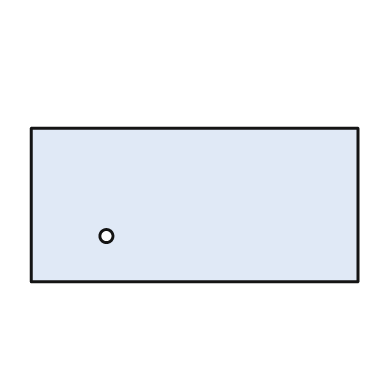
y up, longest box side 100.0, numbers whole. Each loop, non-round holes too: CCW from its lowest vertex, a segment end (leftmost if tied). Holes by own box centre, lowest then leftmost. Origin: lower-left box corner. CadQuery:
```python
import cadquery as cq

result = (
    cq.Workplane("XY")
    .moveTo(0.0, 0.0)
    .lineTo(100.0, 0.0)
    .lineTo(100.0, 47.0)
    .lineTo(0.0, 47.0)
    .close()
    .moveTo(23.0, 14.0)
    .circle(2.0)
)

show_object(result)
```